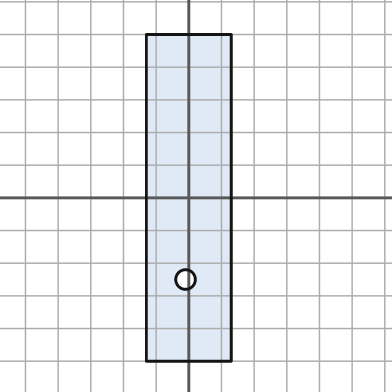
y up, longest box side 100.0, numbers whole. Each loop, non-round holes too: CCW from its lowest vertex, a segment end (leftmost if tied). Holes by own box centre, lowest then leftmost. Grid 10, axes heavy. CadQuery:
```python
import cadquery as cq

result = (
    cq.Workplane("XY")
    .moveTo(-13.0, -50.0)
    .lineTo(13.0, -50.0)
    .lineTo(13.0, 50.0)
    .lineTo(-13.0, 50.0)
    .close()
    .moveTo(-1.0, -25.0)
    .circle(3.0)
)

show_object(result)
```